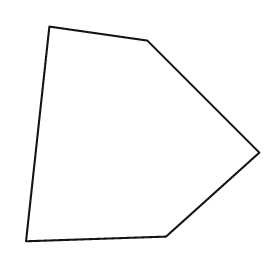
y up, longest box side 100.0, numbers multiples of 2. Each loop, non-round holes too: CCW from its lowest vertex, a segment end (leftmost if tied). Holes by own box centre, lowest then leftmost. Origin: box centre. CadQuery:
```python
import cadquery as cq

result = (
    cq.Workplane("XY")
    .moveTo(-50.0, -46.0)
    .lineTo(10.0, -44.0)
    .lineTo(50.0, -8.0)
    .lineTo(2.0, 40.0)
    .lineTo(-40.0, 46.0)
    .close()
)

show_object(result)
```